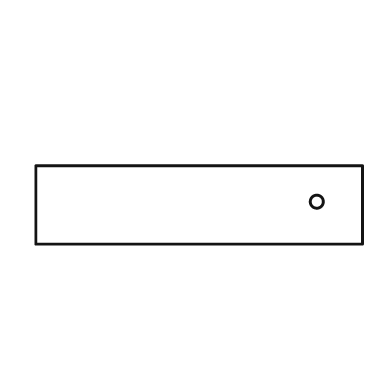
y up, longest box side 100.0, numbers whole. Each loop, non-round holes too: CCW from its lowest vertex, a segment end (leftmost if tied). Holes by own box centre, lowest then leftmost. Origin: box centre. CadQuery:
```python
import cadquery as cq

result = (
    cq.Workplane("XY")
    .moveTo(-50.0, -12.0)
    .lineTo(50.0, -12.0)
    .lineTo(50.0, 12.0)
    .lineTo(-50.0, 12.0)
    .close()
    .moveTo(36.0, 1.0)
    .circle(2.0)
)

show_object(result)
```